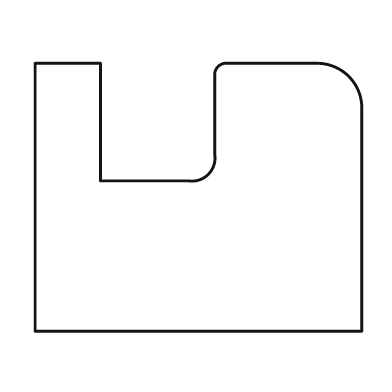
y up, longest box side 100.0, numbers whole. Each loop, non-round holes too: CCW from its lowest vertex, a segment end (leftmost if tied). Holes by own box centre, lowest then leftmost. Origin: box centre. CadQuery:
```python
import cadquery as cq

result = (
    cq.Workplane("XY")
    .moveTo(-50.0, -41.0)
    .lineTo(50.0, -41.0)
    .lineTo(50.0, 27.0)
    .threePointArc((46.0, 37.0), (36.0, 41.0))
    .lineTo(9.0, 41.0)
    .threePointArc((6.0, 40.0), (5.0, 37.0))
    .lineTo(5.0, 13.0)
    .threePointArc((3.0, 7.0), (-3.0, 5.0))
    .lineTo(-30.0, 5.0)
    .lineTo(-30.0, 41.0)
    .lineTo(-50.0, 41.0)
    .close()
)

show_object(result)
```